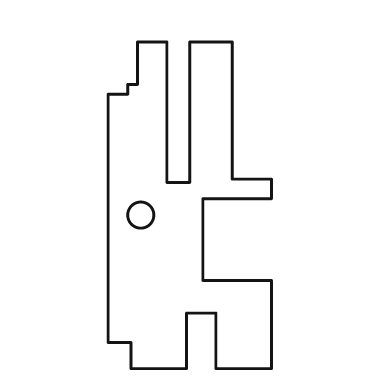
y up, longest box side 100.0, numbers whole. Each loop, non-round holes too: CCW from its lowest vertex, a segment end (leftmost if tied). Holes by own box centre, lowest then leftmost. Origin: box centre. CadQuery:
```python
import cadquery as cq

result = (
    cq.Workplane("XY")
    .moveTo(-18.0, -50.0)
    .lineTo(-1.0, -50.0)
    .lineTo(-1.0, -33.0)
    .lineTo(8.0, -33.0)
    .lineTo(8.0, -50.0)
    .lineTo(25.0, -50.0)
    .lineTo(25.0, -23.0)
    .lineTo(4.0, -23.0)
    .lineTo(4.0, 2.0)
    .lineTo(25.0, 2.0)
    .lineTo(25.0, 8.0)
    .lineTo(13.0, 8.0)
    .lineTo(13.0, 50.0)
    .lineTo(0.0, 50.0)
    .lineTo(0.0, 7.0)
    .lineTo(-7.0, 7.0)
    .lineTo(-7.0, 50.0)
    .lineTo(-16.0, 50.0)
    .lineTo(-16.0, 37.0)
    .lineTo(-19.0, 37.0)
    .lineTo(-19.0, 34.0)
    .lineTo(-25.0, 34.0)
    .lineTo(-25.0, -42.0)
    .lineTo(-18.0, -42.0)
    .close()
    .moveTo(-15.0, -3.0)
    .circle(4.0)
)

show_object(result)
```